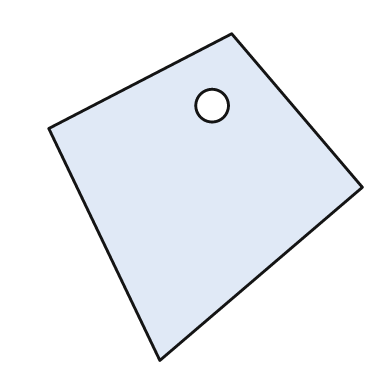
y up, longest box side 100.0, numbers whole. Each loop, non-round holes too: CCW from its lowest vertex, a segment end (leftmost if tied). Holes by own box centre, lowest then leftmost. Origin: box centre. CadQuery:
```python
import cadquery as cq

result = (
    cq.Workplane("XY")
    .moveTo(-14.0, -50.0)
    .lineTo(48.0, 3.0)
    .lineTo(8.0, 50.0)
    .lineTo(-48.0, 21.0)
    .close()
    .moveTo(2.0, 28.0)
    .circle(5.0)
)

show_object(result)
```